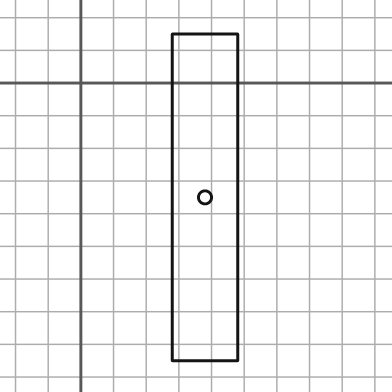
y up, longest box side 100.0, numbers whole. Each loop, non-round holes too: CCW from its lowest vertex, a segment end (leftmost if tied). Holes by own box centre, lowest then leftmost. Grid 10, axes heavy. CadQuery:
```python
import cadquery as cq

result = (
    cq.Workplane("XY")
    .moveTo(28.0, -85.0)
    .lineTo(48.0, -85.0)
    .lineTo(48.0, 15.0)
    .lineTo(28.0, 15.0)
    .close()
    .moveTo(38.0, -35.0)
    .circle(2.0)
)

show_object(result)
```